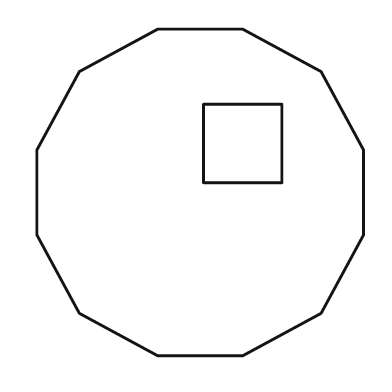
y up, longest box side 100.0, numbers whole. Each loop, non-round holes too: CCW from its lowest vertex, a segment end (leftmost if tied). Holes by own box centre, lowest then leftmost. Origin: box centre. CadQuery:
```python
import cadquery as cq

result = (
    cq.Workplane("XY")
    .moveTo(-13.0, -50.0)
    .lineTo(13.0, -50.0)
    .lineTo(37.0, -37.0)
    .lineTo(50.0, -13.0)
    .lineTo(50.0, 13.0)
    .lineTo(37.0, 37.0)
    .lineTo(13.0, 50.0)
    .lineTo(-13.0, 50.0)
    .lineTo(-37.0, 37.0)
    .lineTo(-50.0, 13.0)
    .lineTo(-50.0, -13.0)
    .lineTo(-37.0, -37.0)
    .close()
    .moveTo(1.0, 3.0)
    .lineTo(25.0, 3.0)
    .lineTo(25.0, 27.0)
    .lineTo(1.0, 27.0)
    .close()
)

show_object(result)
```